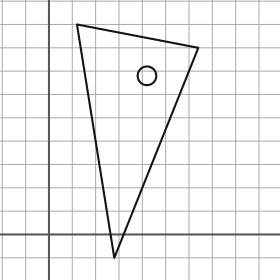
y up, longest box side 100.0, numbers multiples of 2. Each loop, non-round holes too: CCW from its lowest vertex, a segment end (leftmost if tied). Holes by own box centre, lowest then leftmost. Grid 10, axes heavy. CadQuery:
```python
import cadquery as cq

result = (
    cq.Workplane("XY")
    .moveTo(28.0, -10.0)
    .lineTo(64.0, 80.0)
    .lineTo(12.0, 90.0)
    .close()
    .moveTo(42.0, 68.0)
    .circle(4.0)
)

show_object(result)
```